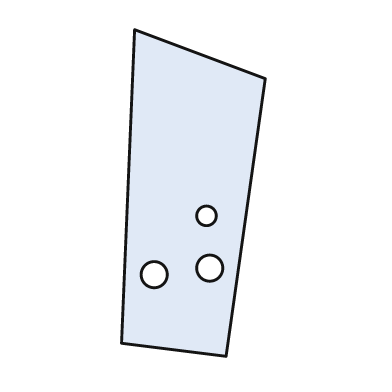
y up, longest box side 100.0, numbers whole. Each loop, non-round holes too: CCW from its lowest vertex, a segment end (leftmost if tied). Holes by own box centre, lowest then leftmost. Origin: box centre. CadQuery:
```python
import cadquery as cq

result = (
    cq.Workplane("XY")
    .moveTo(10.0, -50.0)
    .lineTo(22.0, 35.0)
    .lineTo(-18.0, 50.0)
    .lineTo(-22.0, -46.0)
    .close()
    .moveTo(-12.0, -25.0)
    .circle(4.0)
    .moveTo(5.0, -23.0)
    .circle(4.0)
    .moveTo(4.0, -7.0)
    .circle(3.0)
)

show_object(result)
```